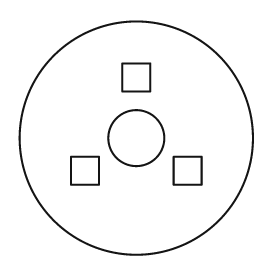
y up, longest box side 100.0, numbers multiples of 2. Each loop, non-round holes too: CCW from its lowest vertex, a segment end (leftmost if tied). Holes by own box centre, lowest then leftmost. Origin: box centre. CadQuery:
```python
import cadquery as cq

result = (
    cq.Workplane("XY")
    .moveTo(0.0, 0.0)
    .circle(50.0)
    .moveTo(-28.0, -20.0)
    .lineTo(-16.0, -20.0)
    .lineTo(-16.0, -8.0)
    .lineTo(-28.0, -8.0)
    .close()
    .moveTo(16.0, -20.0)
    .lineTo(28.0, -20.0)
    .lineTo(28.0, -8.0)
    .lineTo(16.0, -8.0)
    .close()
    .moveTo(0.0, 0.0)
    .circle(12.0)
    .moveTo(-6.0, 20.0)
    .lineTo(6.0, 20.0)
    .lineTo(6.0, 32.0)
    .lineTo(-6.0, 32.0)
    .close()
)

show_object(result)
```